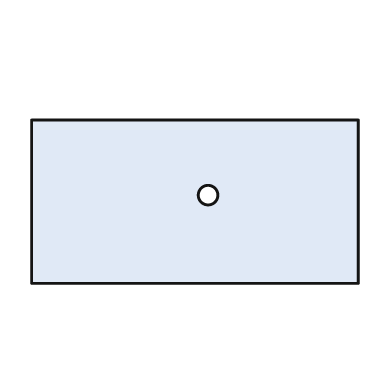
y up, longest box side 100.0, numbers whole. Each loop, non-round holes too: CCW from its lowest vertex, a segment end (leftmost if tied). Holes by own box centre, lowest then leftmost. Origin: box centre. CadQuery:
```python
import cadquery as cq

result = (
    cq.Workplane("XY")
    .moveTo(-50.0, -25.0)
    .lineTo(50.0, -25.0)
    .lineTo(50.0, 25.0)
    .lineTo(-50.0, 25.0)
    .close()
    .moveTo(4.0, 2.0)
    .circle(3.0)
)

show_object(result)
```